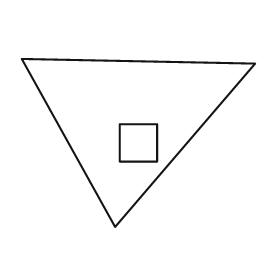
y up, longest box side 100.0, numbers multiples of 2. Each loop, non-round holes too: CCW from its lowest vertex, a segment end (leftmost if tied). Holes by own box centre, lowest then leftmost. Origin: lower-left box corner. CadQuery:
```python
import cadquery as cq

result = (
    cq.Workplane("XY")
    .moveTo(40.0, 0.0)
    .lineTo(100.0, 70.0)
    .lineTo(0.0, 72.0)
    .close()
    .moveTo(42.0, 28.0)
    .lineTo(58.0, 28.0)
    .lineTo(58.0, 44.0)
    .lineTo(42.0, 44.0)
    .close()
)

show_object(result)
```